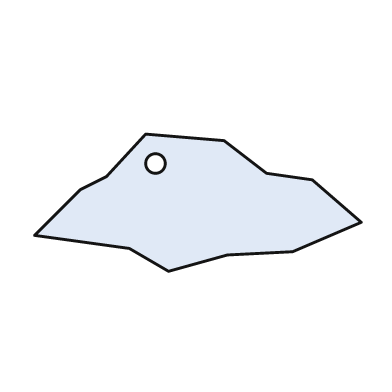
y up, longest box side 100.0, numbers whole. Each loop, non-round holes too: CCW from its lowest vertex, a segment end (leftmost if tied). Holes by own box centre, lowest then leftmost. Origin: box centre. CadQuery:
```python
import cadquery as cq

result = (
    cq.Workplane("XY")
    .moveTo(-9.0, -21.0)
    .lineTo(9.0, -16.0)
    .lineTo(29.0, -15.0)
    .lineTo(50.0, -6.0)
    .lineTo(35.0, 7.0)
    .lineTo(21.0, 9.0)
    .lineTo(8.0, 19.0)
    .lineTo(-16.0, 21.0)
    .lineTo(-28.0, 8.0)
    .lineTo(-36.0, 4.0)
    .lineTo(-50.0, -10.0)
    .lineTo(-21.0, -14.0)
    .close()
    .moveTo(-13.0, 12.0)
    .circle(3.0)
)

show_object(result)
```